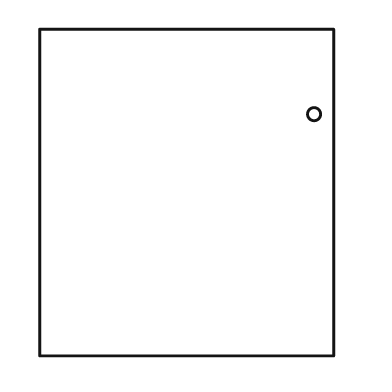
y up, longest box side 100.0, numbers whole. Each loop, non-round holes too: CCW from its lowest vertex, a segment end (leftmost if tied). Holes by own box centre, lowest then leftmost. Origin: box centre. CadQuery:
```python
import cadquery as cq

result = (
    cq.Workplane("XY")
    .moveTo(-45.0, -50.0)
    .lineTo(45.0, -50.0)
    .lineTo(45.0, 50.0)
    .lineTo(-45.0, 50.0)
    .close()
    .moveTo(39.0, 24.0)
    .circle(2.0)
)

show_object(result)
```